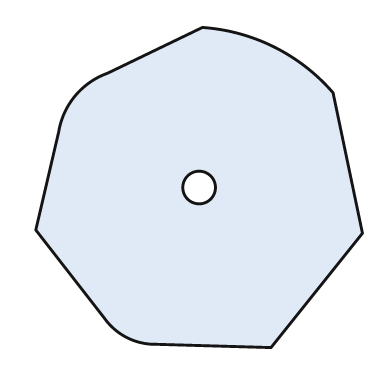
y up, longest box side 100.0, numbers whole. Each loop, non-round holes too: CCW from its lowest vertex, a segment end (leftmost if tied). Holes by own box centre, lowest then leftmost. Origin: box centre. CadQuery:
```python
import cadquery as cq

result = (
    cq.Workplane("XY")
    .moveTo(22.0, -49.0)
    .lineTo(50.0, -14.0)
    .lineTo(41.0, 29.0)
    .threePointArc((23.0, 43.0), (1.0, 49.0))
    .lineTo(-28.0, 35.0)
    .threePointArc((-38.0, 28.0), (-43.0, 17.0))
    .lineTo(-50.0, -13.0)
    .lineTo(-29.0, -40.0)
    .threePointArc((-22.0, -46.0), (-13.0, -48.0))
    .close()
    .moveTo(0.0, 0.0)
    .circle(5.0)
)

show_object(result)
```